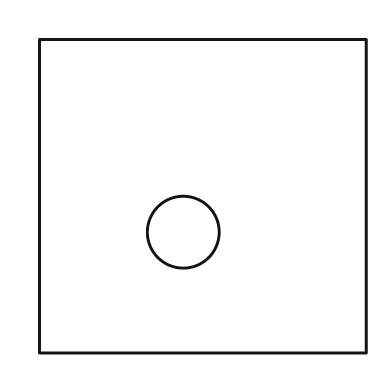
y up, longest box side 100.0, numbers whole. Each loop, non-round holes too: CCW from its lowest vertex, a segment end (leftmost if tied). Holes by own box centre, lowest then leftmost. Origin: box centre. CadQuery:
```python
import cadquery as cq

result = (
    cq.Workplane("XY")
    .moveTo(-50.0, -48.0)
    .lineTo(50.0, -48.0)
    .lineTo(50.0, 48.0)
    .lineTo(-50.0, 48.0)
    .close()
    .moveTo(-6.0, -11.0)
    .circle(11.0)
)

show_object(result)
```